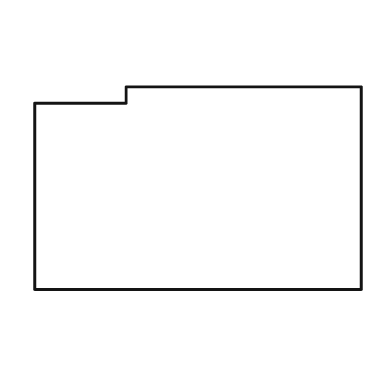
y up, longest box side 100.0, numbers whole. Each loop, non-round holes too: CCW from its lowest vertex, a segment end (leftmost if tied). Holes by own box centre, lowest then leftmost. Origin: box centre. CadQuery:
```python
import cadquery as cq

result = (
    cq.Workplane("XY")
    .moveTo(-50.0, -31.0)
    .lineTo(50.0, -31.0)
    .lineTo(50.0, 31.0)
    .lineTo(-22.0, 31.0)
    .lineTo(-22.0, 26.0)
    .lineTo(-50.0, 26.0)
    .close()
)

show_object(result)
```